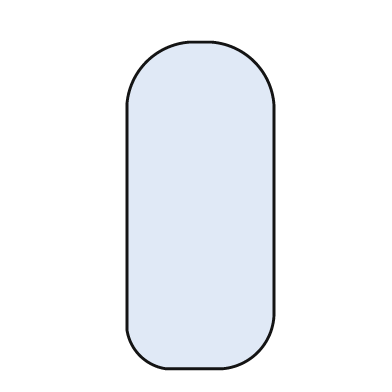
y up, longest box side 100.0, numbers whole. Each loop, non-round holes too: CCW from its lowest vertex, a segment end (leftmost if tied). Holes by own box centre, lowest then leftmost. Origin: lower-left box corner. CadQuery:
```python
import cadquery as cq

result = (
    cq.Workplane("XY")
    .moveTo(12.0, 0.0)
    .lineTo(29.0, 0.0)
    .threePointArc((40.0, 5.0), (45.0, 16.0))
    .lineTo(45.0, 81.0)
    .threePointArc((39.0, 94.0), (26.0, 100.0))
    .lineTo(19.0, 100.0)
    .threePointArc((6.0, 94.0), (0.0, 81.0))
    .lineTo(0.0, 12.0)
    .threePointArc((4.0, 4.0), (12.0, 0.0))
    .close()
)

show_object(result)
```